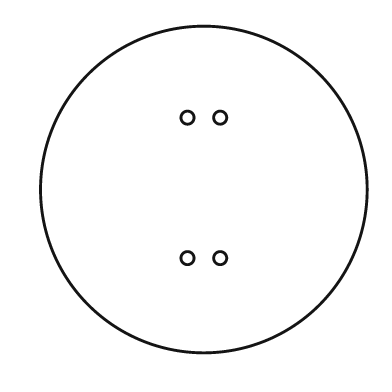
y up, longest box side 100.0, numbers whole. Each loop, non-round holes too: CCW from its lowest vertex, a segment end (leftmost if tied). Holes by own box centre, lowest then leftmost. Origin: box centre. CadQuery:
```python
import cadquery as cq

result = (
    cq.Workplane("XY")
    .moveTo(0.0, 0.0)
    .circle(50.0)
    .moveTo(-5.0, -21.0)
    .circle(2.0)
    .moveTo(5.0, -21.0)
    .circle(2.0)
    .moveTo(-5.0, 22.0)
    .circle(2.0)
    .moveTo(5.0, 22.0)
    .circle(2.0)
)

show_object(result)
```